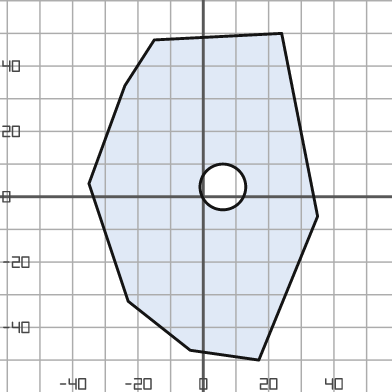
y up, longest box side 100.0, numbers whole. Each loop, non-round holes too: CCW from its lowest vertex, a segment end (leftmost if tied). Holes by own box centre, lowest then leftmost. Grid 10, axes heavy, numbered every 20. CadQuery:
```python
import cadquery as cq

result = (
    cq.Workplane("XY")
    .moveTo(17.0, -50.0)
    .lineTo(35.0, -6.0)
    .lineTo(24.0, 50.0)
    .lineTo(-15.0, 48.0)
    .lineTo(-24.0, 34.0)
    .lineTo(-35.0, 4.0)
    .lineTo(-23.0, -32.0)
    .lineTo(-4.0, -47.0)
    .close()
    .moveTo(6.0, 3.0)
    .circle(7.0)
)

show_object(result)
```